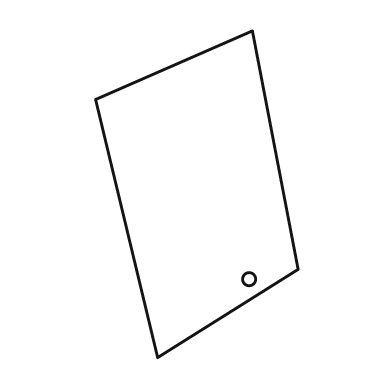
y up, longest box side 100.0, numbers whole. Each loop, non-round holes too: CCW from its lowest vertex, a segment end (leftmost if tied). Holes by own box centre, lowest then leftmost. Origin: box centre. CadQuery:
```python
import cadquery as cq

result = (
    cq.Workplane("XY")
    .moveTo(-12.0, -50.0)
    .lineTo(31.0, -23.0)
    .lineTo(17.0, 50.0)
    .lineTo(-31.0, 29.0)
    .close()
    .moveTo(16.0, -26.0)
    .circle(2.0)
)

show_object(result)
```